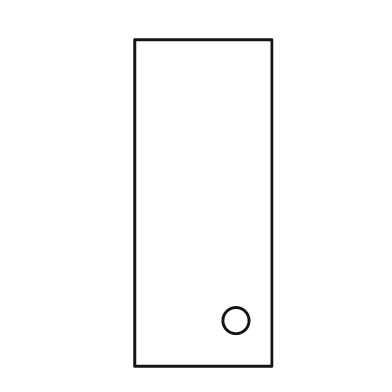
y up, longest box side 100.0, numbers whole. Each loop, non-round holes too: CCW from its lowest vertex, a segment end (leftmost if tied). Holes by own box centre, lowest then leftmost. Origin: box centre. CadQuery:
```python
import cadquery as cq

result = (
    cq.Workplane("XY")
    .moveTo(-21.0, -50.0)
    .lineTo(21.0, -50.0)
    .lineTo(21.0, 50.0)
    .lineTo(-21.0, 50.0)
    .close()
    .moveTo(10.0, -36.0)
    .circle(4.0)
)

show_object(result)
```